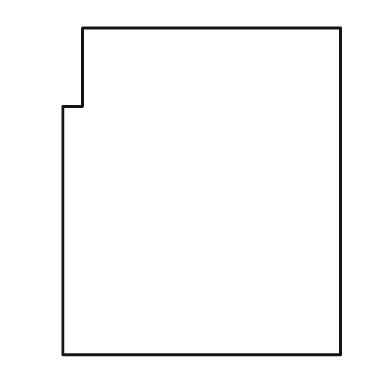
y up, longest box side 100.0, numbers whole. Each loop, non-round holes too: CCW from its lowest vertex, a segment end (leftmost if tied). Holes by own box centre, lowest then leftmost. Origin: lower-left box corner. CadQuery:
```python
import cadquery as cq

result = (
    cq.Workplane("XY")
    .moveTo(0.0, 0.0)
    .lineTo(85.0, 0.0)
    .lineTo(85.0, 100.0)
    .lineTo(6.0, 100.0)
    .lineTo(6.0, 76.0)
    .lineTo(0.0, 76.0)
    .close()
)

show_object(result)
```